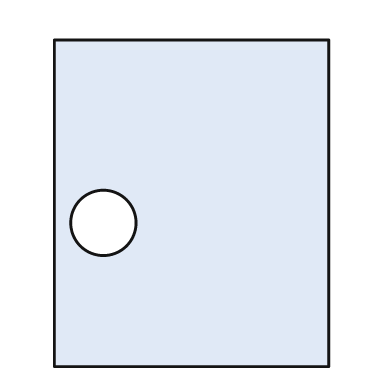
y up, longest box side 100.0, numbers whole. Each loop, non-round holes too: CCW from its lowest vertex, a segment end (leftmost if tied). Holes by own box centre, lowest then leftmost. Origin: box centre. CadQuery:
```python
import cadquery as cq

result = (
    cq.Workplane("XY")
    .moveTo(-42.0, -50.0)
    .lineTo(42.0, -50.0)
    .lineTo(42.0, 50.0)
    .lineTo(-42.0, 50.0)
    .close()
    .moveTo(-27.0, -6.0)
    .circle(10.0)
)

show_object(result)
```